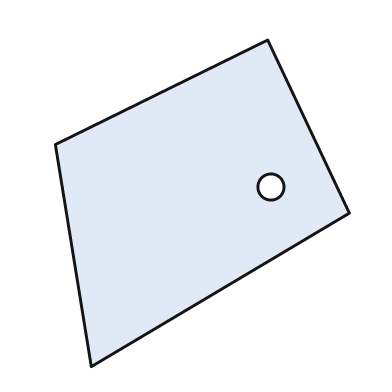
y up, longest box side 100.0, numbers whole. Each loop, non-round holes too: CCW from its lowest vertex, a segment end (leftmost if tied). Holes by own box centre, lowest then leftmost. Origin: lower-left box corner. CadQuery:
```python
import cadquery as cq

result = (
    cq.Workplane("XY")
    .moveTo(11.0, 0.0)
    .lineTo(90.0, 47.0)
    .lineTo(65.0, 100.0)
    .lineTo(0.0, 68.0)
    .close()
    .moveTo(66.0, 55.0)
    .circle(4.0)
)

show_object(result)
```